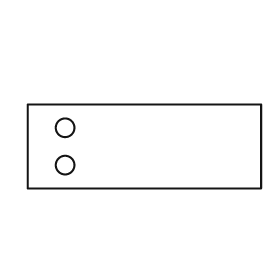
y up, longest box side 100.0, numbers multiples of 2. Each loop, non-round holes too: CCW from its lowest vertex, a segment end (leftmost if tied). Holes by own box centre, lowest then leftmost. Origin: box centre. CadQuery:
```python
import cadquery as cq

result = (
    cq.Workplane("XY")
    .moveTo(-50.0, -18.0)
    .lineTo(50.0, -18.0)
    .lineTo(50.0, 18.0)
    .lineTo(-50.0, 18.0)
    .close()
    .moveTo(-34.0, -8.0)
    .circle(4.0)
    .moveTo(-34.0, 8.0)
    .circle(4.0)
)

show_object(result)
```